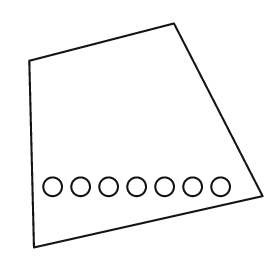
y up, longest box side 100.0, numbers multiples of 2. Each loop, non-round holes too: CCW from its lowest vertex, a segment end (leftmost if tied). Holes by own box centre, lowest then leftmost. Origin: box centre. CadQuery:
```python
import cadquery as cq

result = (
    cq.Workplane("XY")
    .moveTo(-48.0, -48.0)
    .lineTo(50.0, -26.0)
    .lineTo(12.0, 48.0)
    .lineTo(-50.0, 32.0)
    .close()
    .moveTo(-40.0, -22.0)
    .circle(4.0)
    .moveTo(-28.0, -22.0)
    .circle(4.0)
    .moveTo(-16.0, -22.0)
    .circle(4.0)
    .moveTo(-4.0, -22.0)
    .circle(4.0)
    .moveTo(8.0, -22.0)
    .circle(4.0)
    .moveTo(20.0, -22.0)
    .circle(4.0)
    .moveTo(32.0, -22.0)
    .circle(4.0)
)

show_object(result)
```